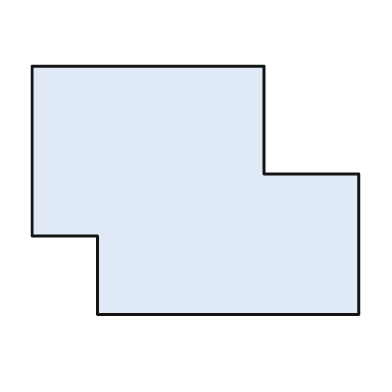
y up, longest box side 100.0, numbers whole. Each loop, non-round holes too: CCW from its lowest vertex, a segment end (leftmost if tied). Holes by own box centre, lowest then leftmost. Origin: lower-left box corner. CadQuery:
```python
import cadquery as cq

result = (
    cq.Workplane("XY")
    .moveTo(20.0, 0.0)
    .lineTo(100.0, 0.0)
    .lineTo(100.0, 43.0)
    .lineTo(71.0, 43.0)
    .lineTo(71.0, 76.0)
    .lineTo(0.0, 76.0)
    .lineTo(0.0, 24.0)
    .lineTo(20.0, 24.0)
    .close()
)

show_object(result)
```